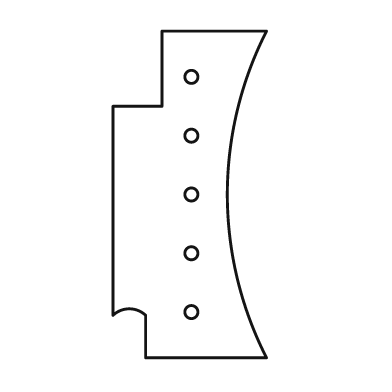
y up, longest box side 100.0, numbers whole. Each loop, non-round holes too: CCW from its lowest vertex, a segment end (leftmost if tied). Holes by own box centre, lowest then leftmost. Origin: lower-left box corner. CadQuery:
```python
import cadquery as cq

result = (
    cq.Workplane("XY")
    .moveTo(10.0, 0.0)
    .lineTo(47.0, 0.0)
    .threePointArc((35.0, 50.0), (47.0, 100.0))
    .lineTo(15.0, 100.0)
    .lineTo(15.0, 77.0)
    .lineTo(0.0, 77.0)
    .lineTo(0.0, 13.0)
    .threePointArc((5.0, 15.0), (10.0, 13.0))
    .close()
    .moveTo(24.0, 14.0)
    .circle(2.0)
    .moveTo(24.0, 32.0)
    .circle(2.0)
    .moveTo(24.0, 50.0)
    .circle(2.0)
    .moveTo(24.0, 68.0)
    .circle(2.0)
    .moveTo(24.0, 86.0)
    .circle(2.0)
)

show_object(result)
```